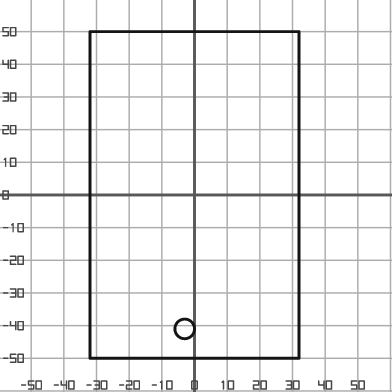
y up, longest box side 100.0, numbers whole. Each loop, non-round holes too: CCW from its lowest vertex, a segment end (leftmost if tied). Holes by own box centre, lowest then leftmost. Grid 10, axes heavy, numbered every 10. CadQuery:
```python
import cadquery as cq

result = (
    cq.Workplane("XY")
    .moveTo(-32.0, -50.0)
    .lineTo(32.0, -50.0)
    .lineTo(32.0, 50.0)
    .lineTo(-32.0, 50.0)
    .close()
    .moveTo(-3.0, -41.0)
    .circle(3.0)
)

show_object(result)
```